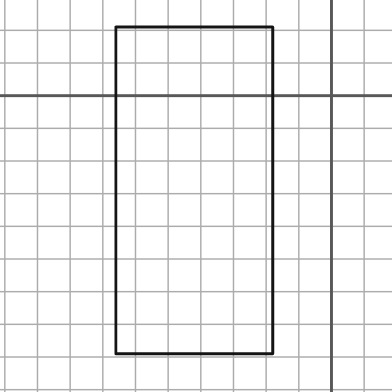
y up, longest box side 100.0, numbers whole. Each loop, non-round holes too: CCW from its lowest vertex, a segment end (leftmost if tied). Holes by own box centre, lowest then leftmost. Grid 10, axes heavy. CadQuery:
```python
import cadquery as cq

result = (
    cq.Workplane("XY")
    .moveTo(-66.0, -79.0)
    .lineTo(-18.0, -79.0)
    .lineTo(-18.0, 21.0)
    .lineTo(-66.0, 21.0)
    .close()
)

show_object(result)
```